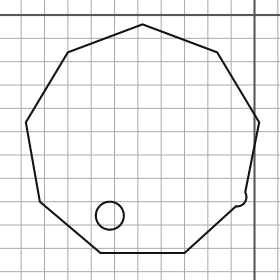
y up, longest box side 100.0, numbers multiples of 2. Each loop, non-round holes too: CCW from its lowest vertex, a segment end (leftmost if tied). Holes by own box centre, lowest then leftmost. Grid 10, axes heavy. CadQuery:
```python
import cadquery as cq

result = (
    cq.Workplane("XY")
    .moveTo(-66.0, -102.0)
    .lineTo(-30.0, -102.0)
    .lineTo(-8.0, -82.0)
    .threePointArc((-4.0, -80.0), (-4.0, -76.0))
    .lineTo(2.0, -46.0)
    .lineTo(-16.0, -16.0)
    .lineTo(-48.0, -4.0)
    .lineTo(-80.0, -16.0)
    .lineTo(-98.0, -46.0)
    .lineTo(-92.0, -80.0)
    .close()
    .moveTo(-62.0, -86.0)
    .circle(6.0)
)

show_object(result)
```